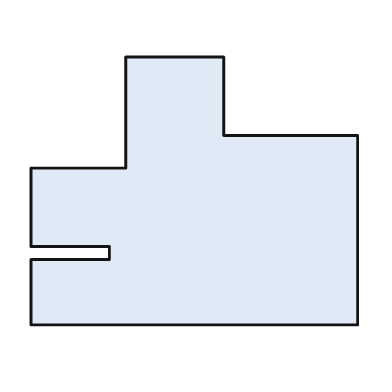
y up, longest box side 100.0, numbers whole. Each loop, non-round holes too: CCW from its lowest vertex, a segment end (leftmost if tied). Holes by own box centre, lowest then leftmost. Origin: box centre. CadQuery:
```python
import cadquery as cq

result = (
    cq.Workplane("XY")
    .moveTo(-50.0, -41.0)
    .lineTo(50.0, -41.0)
    .lineTo(50.0, 17.0)
    .lineTo(9.0, 17.0)
    .lineTo(9.0, 41.0)
    .lineTo(-21.0, 41.0)
    .lineTo(-21.0, 7.0)
    .lineTo(-50.0, 7.0)
    .lineTo(-50.0, -17.0)
    .lineTo(-26.0, -17.0)
    .lineTo(-26.0, -21.0)
    .lineTo(-50.0, -21.0)
    .close()
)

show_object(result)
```